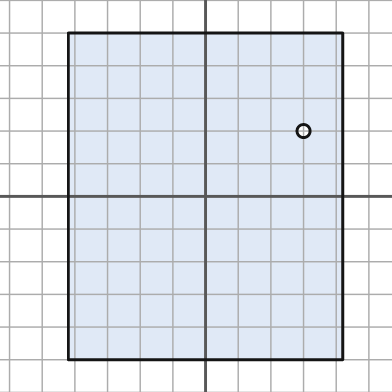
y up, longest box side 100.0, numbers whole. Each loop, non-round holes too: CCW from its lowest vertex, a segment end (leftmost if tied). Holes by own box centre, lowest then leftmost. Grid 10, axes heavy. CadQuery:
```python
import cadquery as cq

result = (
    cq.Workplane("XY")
    .moveTo(-42.0, -50.0)
    .lineTo(42.0, -50.0)
    .lineTo(42.0, 50.0)
    .lineTo(-42.0, 50.0)
    .close()
    .moveTo(30.0, 20.0)
    .circle(2.0)
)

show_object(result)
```